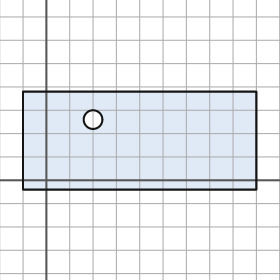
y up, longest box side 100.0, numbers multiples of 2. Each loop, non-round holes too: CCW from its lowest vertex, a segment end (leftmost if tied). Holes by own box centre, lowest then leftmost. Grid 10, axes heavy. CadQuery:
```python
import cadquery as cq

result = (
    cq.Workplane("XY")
    .moveTo(-10.0, -4.0)
    .lineTo(90.0, -4.0)
    .lineTo(90.0, 38.0)
    .lineTo(-10.0, 38.0)
    .close()
    .moveTo(20.0, 26.0)
    .circle(4.0)
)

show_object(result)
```